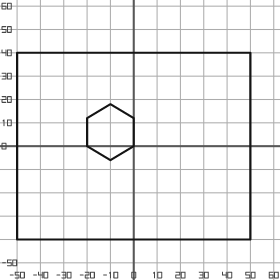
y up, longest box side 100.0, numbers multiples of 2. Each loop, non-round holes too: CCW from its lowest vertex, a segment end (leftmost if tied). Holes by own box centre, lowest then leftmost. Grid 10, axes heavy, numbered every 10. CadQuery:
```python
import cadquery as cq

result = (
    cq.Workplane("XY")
    .moveTo(-50.0, -40.0)
    .lineTo(50.0, -40.0)
    .lineTo(50.0, 40.0)
    .lineTo(-50.0, 40.0)
    .close()
    .moveTo(-10.0, -6.0)
    .lineTo(0.0, 0.0)
    .lineTo(0.0, 12.0)
    .lineTo(-10.0, 18.0)
    .lineTo(-20.0, 12.0)
    .lineTo(-20.0, 0.0)
    .close()
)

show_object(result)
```